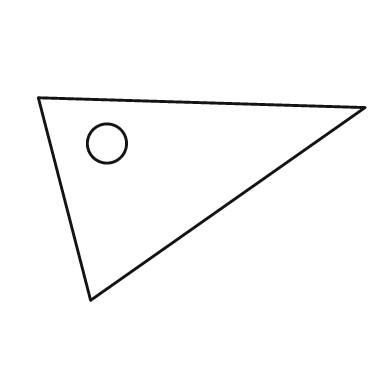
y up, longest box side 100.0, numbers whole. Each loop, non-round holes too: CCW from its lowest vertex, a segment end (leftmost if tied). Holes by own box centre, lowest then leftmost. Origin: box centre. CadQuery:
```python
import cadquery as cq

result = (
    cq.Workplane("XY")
    .moveTo(-34.0, -31.0)
    .lineTo(50.0, 28.0)
    .lineTo(-50.0, 31.0)
    .close()
    .moveTo(-29.0, 17.0)
    .circle(6.0)
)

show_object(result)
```